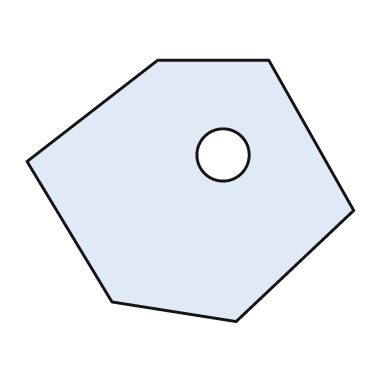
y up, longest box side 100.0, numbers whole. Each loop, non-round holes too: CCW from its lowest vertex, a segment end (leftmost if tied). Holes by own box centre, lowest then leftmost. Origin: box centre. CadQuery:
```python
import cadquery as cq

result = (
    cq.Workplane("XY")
    .moveTo(14.0, -40.0)
    .lineTo(50.0, -6.0)
    .lineTo(24.0, 40.0)
    .lineTo(-10.0, 40.0)
    .lineTo(-50.0, 9.0)
    .lineTo(-24.0, -34.0)
    .close()
    .moveTo(10.0, 11.0)
    .circle(8.0)
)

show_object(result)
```